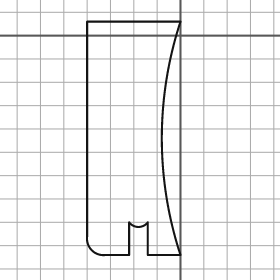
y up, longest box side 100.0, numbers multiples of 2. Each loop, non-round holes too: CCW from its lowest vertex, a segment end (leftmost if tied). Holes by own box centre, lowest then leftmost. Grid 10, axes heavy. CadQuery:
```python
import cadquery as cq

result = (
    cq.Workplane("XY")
    .moveTo(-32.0, -94.0)
    .lineTo(-22.0, -94.0)
    .lineTo(-22.0, -80.0)
    .threePointArc((-18.0, -82.0), (-14.0, -80.0))
    .lineTo(-14.0, -94.0)
    .lineTo(0.0, -94.0)
    .threePointArc((-8.0, -44.0), (0.0, 6.0))
    .lineTo(-40.0, 6.0)
    .lineTo(-40.0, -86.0)
    .threePointArc((-38.0, -92.0), (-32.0, -94.0))
    .close()
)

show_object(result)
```